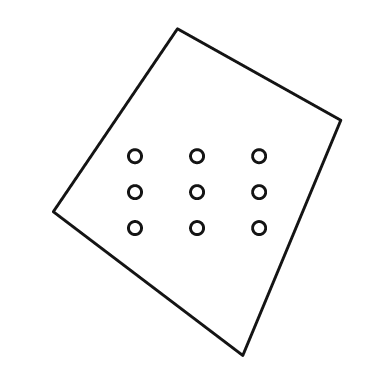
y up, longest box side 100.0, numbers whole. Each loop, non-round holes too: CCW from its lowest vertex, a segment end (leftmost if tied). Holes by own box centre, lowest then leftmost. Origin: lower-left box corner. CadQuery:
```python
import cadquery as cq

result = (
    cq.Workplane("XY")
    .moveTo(58.0, 0.0)
    .lineTo(88.0, 72.0)
    .lineTo(38.0, 100.0)
    .lineTo(0.0, 44.0)
    .close()
    .moveTo(25.0, 39.0)
    .circle(2.0)
    .moveTo(44.0, 39.0)
    .circle(2.0)
    .moveTo(63.0, 39.0)
    .circle(2.0)
    .moveTo(25.0, 50.0)
    .circle(2.0)
    .moveTo(44.0, 50.0)
    .circle(2.0)
    .moveTo(63.0, 50.0)
    .circle(2.0)
    .moveTo(25.0, 61.0)
    .circle(2.0)
    .moveTo(44.0, 61.0)
    .circle(2.0)
    .moveTo(63.0, 61.0)
    .circle(2.0)
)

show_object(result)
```